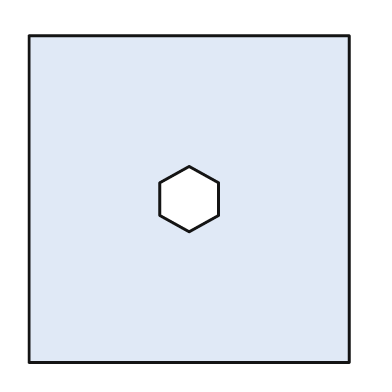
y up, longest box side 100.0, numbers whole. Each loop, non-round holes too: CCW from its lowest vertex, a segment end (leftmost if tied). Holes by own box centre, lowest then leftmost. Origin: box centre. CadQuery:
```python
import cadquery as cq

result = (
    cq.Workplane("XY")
    .moveTo(-49.0, -50.0)
    .lineTo(49.0, -50.0)
    .lineTo(49.0, 50.0)
    .lineTo(-49.0, 50.0)
    .close()
    .moveTo(0.0, -10.0)
    .lineTo(9.0, -5.0)
    .lineTo(9.0, 5.0)
    .lineTo(0.0, 10.0)
    .lineTo(-9.0, 5.0)
    .lineTo(-9.0, -5.0)
    .close()
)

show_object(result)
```